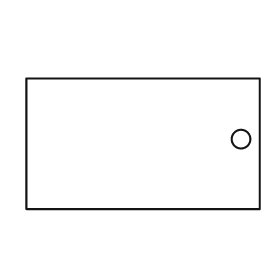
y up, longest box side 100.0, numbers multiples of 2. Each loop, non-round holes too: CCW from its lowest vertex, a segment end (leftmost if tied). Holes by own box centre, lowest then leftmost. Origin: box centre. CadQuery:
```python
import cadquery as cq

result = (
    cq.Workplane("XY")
    .moveTo(-50.0, -28.0)
    .lineTo(50.0, -28.0)
    .lineTo(50.0, 28.0)
    .lineTo(-50.0, 28.0)
    .close()
    .moveTo(42.0, 2.0)
    .circle(4.0)
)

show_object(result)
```